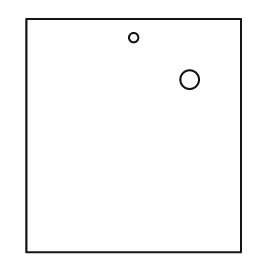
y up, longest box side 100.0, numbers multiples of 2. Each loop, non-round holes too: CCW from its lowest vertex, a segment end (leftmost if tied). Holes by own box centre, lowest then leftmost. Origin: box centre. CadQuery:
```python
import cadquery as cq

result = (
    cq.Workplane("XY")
    .moveTo(-46.0, -50.0)
    .lineTo(46.0, -50.0)
    .lineTo(46.0, 50.0)
    .lineTo(-46.0, 50.0)
    .close()
    .moveTo(24.0, 24.0)
    .circle(4.0)
    .moveTo(0.0, 42.0)
    .circle(2.0)
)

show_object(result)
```